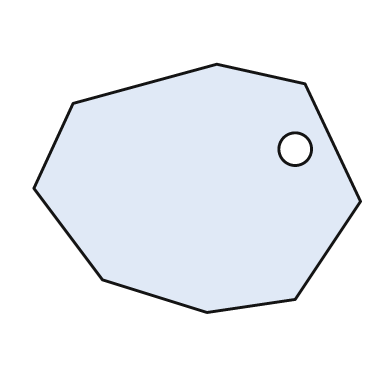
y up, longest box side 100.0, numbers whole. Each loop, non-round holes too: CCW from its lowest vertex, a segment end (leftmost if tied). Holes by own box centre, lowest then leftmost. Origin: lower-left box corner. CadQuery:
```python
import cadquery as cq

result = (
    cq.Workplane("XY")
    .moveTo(53.0, 0.0)
    .lineTo(80.0, 4.0)
    .lineTo(100.0, 34.0)
    .lineTo(83.0, 70.0)
    .lineTo(56.0, 76.0)
    .lineTo(12.0, 64.0)
    .lineTo(0.0, 38.0)
    .lineTo(21.0, 10.0)
    .close()
    .moveTo(80.0, 50.0)
    .circle(5.0)
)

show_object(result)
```